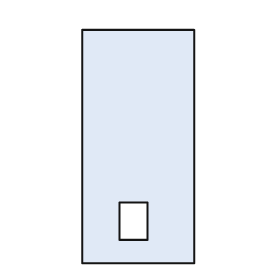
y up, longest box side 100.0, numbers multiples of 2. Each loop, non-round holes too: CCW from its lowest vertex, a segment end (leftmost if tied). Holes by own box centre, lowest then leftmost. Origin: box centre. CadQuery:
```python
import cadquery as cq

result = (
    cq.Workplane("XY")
    .moveTo(-24.0, -50.0)
    .lineTo(24.0, -50.0)
    .lineTo(24.0, 50.0)
    .lineTo(-24.0, 50.0)
    .close()
    .moveTo(-8.0, -40.0)
    .lineTo(4.0, -40.0)
    .lineTo(4.0, -24.0)
    .lineTo(-8.0, -24.0)
    .close()
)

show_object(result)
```